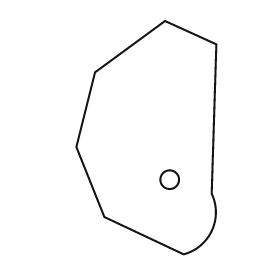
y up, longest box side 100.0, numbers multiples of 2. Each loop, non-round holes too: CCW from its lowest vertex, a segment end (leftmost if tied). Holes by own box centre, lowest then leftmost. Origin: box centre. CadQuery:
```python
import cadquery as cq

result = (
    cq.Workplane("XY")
    .moveTo(16.0, -50.0)
    .threePointArc((28.0, -40.0), (28.0, -24.0))
    .lineTo(30.0, 40.0)
    .lineTo(8.0, 50.0)
    .lineTo(-22.0, 28.0)
    .lineTo(-30.0, -4.0)
    .lineTo(-18.0, -34.0)
    .close()
    .moveTo(10.0, -18.0)
    .circle(4.0)
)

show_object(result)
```